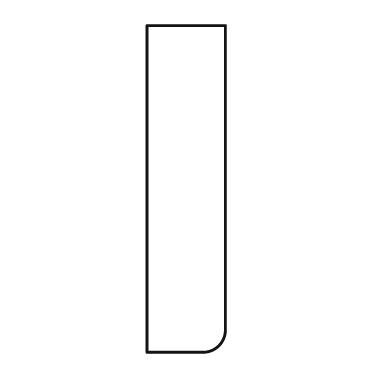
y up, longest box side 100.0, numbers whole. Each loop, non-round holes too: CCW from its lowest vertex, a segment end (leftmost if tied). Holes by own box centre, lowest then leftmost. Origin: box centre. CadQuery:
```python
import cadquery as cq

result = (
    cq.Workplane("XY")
    .moveTo(-12.0, -50.0)
    .lineTo(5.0, -50.0)
    .threePointArc((10.0, -48.0), (12.0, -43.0))
    .lineTo(12.0, 50.0)
    .lineTo(-12.0, 50.0)
    .close()
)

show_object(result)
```